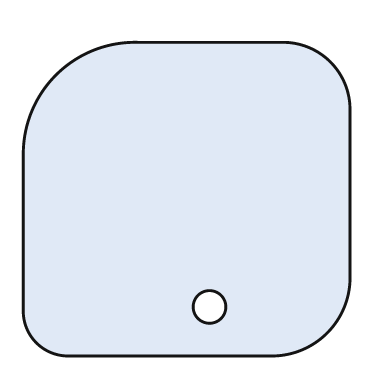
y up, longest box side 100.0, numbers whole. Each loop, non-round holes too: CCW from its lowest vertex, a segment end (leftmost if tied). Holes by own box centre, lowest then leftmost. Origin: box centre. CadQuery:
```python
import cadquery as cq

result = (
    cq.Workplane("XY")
    .moveTo(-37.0, -48.0)
    .lineTo(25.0, -48.0)
    .threePointArc((43.0, -41.0), (50.0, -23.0))
    .lineTo(50.0, 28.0)
    .threePointArc((44.0, 42.0), (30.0, 48.0))
    .lineTo(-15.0, 48.0)
    .threePointArc((-40.0, 38.0), (-50.0, 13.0))
    .lineTo(-50.0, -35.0)
    .threePointArc((-46.0, -44.0), (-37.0, -48.0))
    .close()
    .moveTo(7.0, -33.0)
    .circle(5.0)
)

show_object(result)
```